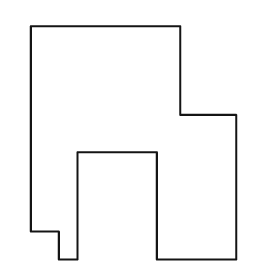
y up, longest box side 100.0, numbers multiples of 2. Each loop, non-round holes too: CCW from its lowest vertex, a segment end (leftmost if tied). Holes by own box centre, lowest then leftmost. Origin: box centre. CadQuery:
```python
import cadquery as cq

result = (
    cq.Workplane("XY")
    .moveTo(-32.0, -50.0)
    .lineTo(-24.0, -50.0)
    .lineTo(-24.0, -4.0)
    .lineTo(10.0, -4.0)
    .lineTo(10.0, -50.0)
    .lineTo(44.0, -50.0)
    .lineTo(44.0, 12.0)
    .lineTo(20.0, 12.0)
    .lineTo(20.0, 50.0)
    .lineTo(-44.0, 50.0)
    .lineTo(-44.0, -38.0)
    .lineTo(-32.0, -38.0)
    .close()
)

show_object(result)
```